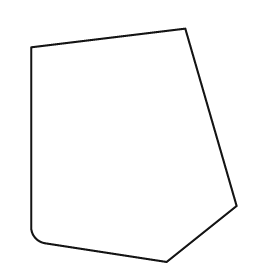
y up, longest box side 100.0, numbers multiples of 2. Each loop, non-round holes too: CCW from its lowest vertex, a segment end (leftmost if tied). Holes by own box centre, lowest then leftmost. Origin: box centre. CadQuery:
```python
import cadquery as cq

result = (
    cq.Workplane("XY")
    .moveTo(14.0, -50.0)
    .lineTo(44.0, -26.0)
    .lineTo(22.0, 50.0)
    .lineTo(-44.0, 42.0)
    .lineTo(-44.0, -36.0)
    .threePointArc((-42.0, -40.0), (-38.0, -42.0))
    .close()
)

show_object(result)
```